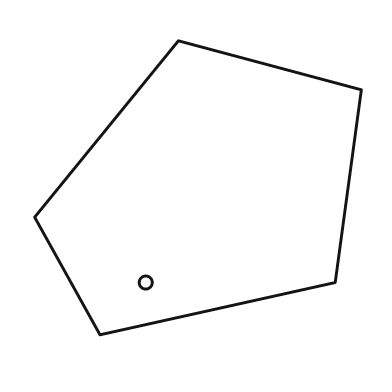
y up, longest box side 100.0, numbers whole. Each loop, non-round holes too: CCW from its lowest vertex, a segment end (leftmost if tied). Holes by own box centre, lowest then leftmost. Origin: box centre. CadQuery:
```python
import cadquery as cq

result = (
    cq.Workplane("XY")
    .moveTo(-30.0, -45.0)
    .lineTo(42.0, -29.0)
    .lineTo(50.0, 30.0)
    .lineTo(-6.0, 45.0)
    .lineTo(-50.0, -9.0)
    .close()
    .moveTo(-16.0, -29.0)
    .circle(2.0)
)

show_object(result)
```